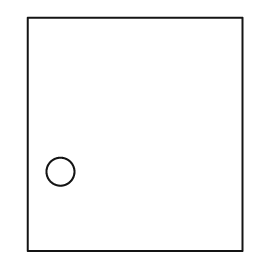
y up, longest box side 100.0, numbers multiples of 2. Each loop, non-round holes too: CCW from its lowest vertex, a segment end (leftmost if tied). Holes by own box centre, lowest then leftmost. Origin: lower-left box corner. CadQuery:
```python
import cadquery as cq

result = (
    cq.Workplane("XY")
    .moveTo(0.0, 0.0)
    .lineTo(92.0, 0.0)
    .lineTo(92.0, 100.0)
    .lineTo(0.0, 100.0)
    .close()
    .moveTo(14.0, 34.0)
    .circle(6.0)
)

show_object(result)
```